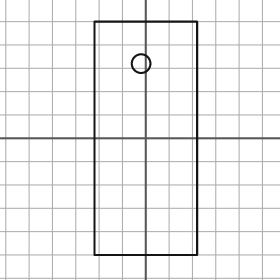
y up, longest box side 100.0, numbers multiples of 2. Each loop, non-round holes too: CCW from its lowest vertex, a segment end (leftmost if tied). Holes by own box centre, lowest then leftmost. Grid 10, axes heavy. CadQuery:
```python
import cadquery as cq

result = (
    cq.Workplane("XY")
    .moveTo(-22.0, -50.0)
    .lineTo(22.0, -50.0)
    .lineTo(22.0, 50.0)
    .lineTo(-22.0, 50.0)
    .close()
    .moveTo(-2.0, 32.0)
    .circle(4.0)
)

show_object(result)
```